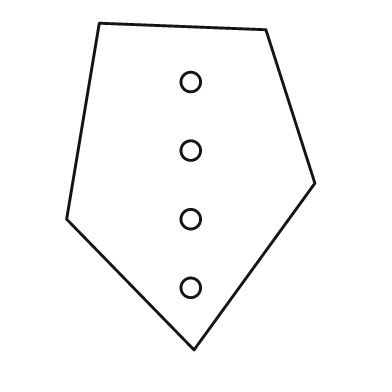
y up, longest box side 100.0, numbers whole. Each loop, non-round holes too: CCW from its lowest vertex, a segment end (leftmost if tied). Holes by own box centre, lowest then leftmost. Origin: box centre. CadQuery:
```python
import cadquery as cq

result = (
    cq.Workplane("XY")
    .moveTo(1.0, -50.0)
    .lineTo(38.0, 1.0)
    .lineTo(23.0, 48.0)
    .lineTo(-28.0, 50.0)
    .lineTo(-38.0, -10.0)
    .close()
    .moveTo(0.0, -31.0)
    .circle(3.0)
    .moveTo(0.0, -10.0)
    .circle(3.0)
    .moveTo(0.0, 11.0)
    .circle(3.0)
    .moveTo(0.0, 32.0)
    .circle(3.0)
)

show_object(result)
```